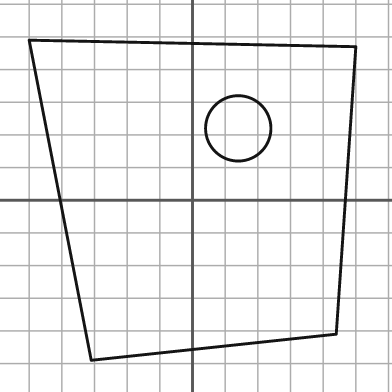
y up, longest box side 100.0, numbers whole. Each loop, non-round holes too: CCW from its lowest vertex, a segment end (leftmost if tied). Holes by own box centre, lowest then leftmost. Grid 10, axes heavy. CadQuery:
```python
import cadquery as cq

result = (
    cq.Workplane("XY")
    .moveTo(-31.0, -49.0)
    .lineTo(44.0, -41.0)
    .lineTo(50.0, 47.0)
    .lineTo(-50.0, 49.0)
    .close()
    .moveTo(14.0, 22.0)
    .circle(10.0)
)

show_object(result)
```